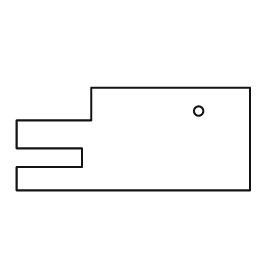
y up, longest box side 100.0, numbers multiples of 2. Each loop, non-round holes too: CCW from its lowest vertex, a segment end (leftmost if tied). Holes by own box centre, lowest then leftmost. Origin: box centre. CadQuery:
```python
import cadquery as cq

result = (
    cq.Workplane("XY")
    .moveTo(-50.0, -22.0)
    .lineTo(50.0, -22.0)
    .lineTo(50.0, 22.0)
    .lineTo(-18.0, 22.0)
    .lineTo(-18.0, 8.0)
    .lineTo(-50.0, 8.0)
    .lineTo(-50.0, -4.0)
    .lineTo(-22.0, -4.0)
    .lineTo(-22.0, -12.0)
    .lineTo(-50.0, -12.0)
    .close()
    .moveTo(28.0, 12.0)
    .circle(2.0)
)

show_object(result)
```